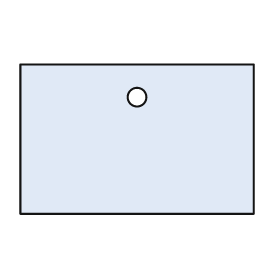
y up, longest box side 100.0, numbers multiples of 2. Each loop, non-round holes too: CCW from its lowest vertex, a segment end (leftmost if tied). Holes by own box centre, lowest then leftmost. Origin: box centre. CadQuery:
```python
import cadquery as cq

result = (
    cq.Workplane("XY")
    .moveTo(-50.0, -32.0)
    .lineTo(50.0, -32.0)
    .lineTo(50.0, 32.0)
    .lineTo(-50.0, 32.0)
    .close()
    .moveTo(0.0, 18.0)
    .circle(4.0)
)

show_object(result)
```